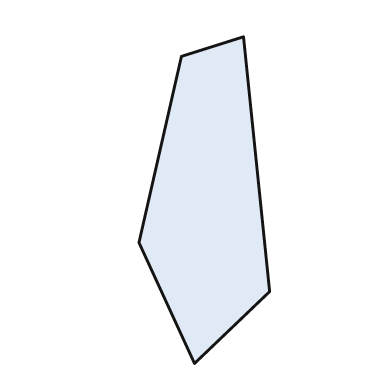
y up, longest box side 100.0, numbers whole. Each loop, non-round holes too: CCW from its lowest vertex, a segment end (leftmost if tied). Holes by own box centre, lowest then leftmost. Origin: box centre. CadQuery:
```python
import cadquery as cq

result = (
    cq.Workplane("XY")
    .moveTo(-3.0, -50.0)
    .lineTo(20.0, -28.0)
    .lineTo(12.0, 50.0)
    .lineTo(-7.0, 44.0)
    .lineTo(-20.0, -13.0)
    .close()
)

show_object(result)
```